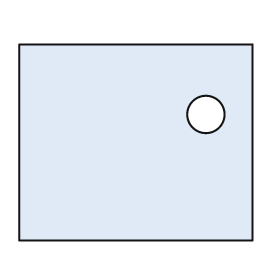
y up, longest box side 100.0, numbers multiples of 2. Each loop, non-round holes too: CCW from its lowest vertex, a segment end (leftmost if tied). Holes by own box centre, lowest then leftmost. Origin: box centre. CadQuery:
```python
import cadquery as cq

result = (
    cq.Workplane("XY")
    .moveTo(-50.0, -42.0)
    .lineTo(50.0, -42.0)
    .lineTo(50.0, 42.0)
    .lineTo(-50.0, 42.0)
    .close()
    .moveTo(30.0, 12.0)
    .circle(8.0)
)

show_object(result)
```